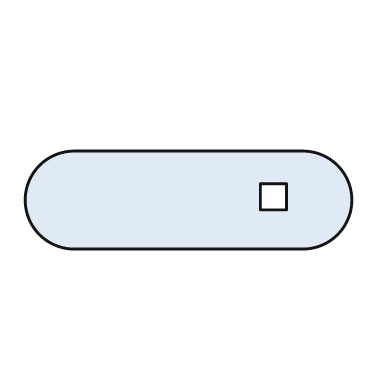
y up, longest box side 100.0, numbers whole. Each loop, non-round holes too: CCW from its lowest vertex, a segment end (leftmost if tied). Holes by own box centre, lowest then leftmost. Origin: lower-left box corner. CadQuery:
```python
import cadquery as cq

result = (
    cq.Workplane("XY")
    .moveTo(15.0, 0.0)
    .lineTo(85.0, 0.0)
    .threePointArc((100.0, 15.0), (85.0, 30.0))
    .lineTo(15.0, 30.0)
    .threePointArc((0.0, 15.0), (15.0, 0.0))
    .close()
    .moveTo(72.0, 12.0)
    .lineTo(80.0, 12.0)
    .lineTo(80.0, 20.0)
    .lineTo(72.0, 20.0)
    .close()
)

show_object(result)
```